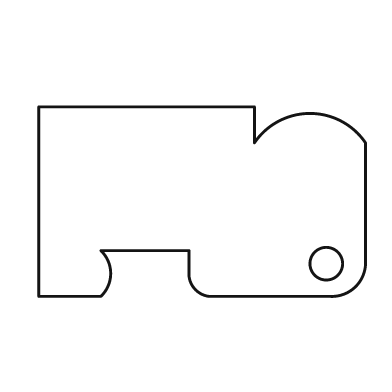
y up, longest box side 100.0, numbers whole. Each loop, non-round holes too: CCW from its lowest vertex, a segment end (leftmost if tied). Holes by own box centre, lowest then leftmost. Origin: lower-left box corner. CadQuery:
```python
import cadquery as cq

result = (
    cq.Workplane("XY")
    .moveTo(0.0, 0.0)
    .lineTo(19.0, 0.0)
    .threePointArc((22.0, 7.0), (19.0, 14.0))
    .lineTo(46.0, 14.0)
    .lineTo(46.0, 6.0)
    .threePointArc((48.0, 2.0), (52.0, 0.0))
    .lineTo(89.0, 0.0)
    .threePointArc((97.0, 3.0), (100.0, 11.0))
    .lineTo(100.0, 47.0)
    .threePointArc((83.0, 56.0), (66.0, 47.0))
    .lineTo(66.0, 58.0)
    .lineTo(0.0, 58.0)
    .close()
    .moveTo(88.0, 10.0)
    .circle(5.0)
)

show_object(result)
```